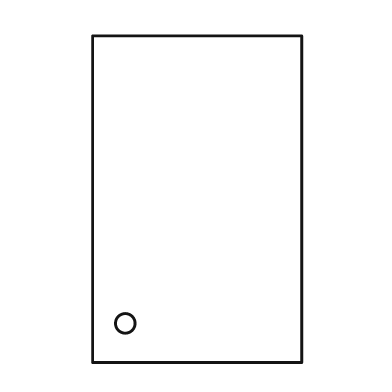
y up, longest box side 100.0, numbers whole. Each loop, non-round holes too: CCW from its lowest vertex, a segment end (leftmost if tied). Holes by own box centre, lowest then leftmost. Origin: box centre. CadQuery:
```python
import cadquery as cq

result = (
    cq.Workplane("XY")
    .moveTo(-32.0, -50.0)
    .lineTo(32.0, -50.0)
    .lineTo(32.0, 50.0)
    .lineTo(-32.0, 50.0)
    .close()
    .moveTo(-22.0, -38.0)
    .circle(3.0)
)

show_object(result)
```